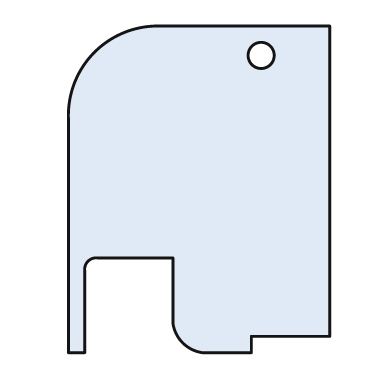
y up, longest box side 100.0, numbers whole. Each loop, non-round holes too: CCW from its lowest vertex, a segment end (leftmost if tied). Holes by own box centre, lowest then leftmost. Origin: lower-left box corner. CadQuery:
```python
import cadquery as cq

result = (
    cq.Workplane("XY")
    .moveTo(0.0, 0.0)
    .lineTo(5.0, 0.0)
    .lineTo(5.0, 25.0)
    .threePointArc((6.0, 28.0), (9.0, 29.0))
    .lineTo(32.0, 29.0)
    .lineTo(32.0, 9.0)
    .threePointArc((35.0, 3.0), (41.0, 0.0))
    .lineTo(56.0, 0.0)
    .lineTo(56.0, 5.0)
    .lineTo(80.0, 5.0)
    .lineTo(80.0, 100.0)
    .lineTo(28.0, 100.0)
    .threePointArc((8.0, 92.0), (0.0, 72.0))
    .close()
    .moveTo(59.0, 91.0)
    .circle(4.0)
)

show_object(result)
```